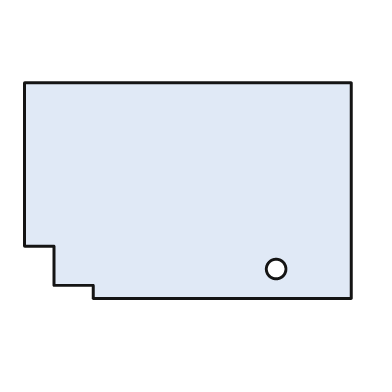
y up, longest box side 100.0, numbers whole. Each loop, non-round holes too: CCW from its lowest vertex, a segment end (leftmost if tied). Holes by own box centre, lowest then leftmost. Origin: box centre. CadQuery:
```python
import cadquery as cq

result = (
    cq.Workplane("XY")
    .moveTo(-29.0, -33.0)
    .lineTo(50.0, -33.0)
    .lineTo(50.0, 33.0)
    .lineTo(-50.0, 33.0)
    .lineTo(-50.0, -17.0)
    .lineTo(-41.0, -17.0)
    .lineTo(-41.0, -29.0)
    .lineTo(-29.0, -29.0)
    .close()
    .moveTo(27.0, -24.0)
    .circle(3.0)
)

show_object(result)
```